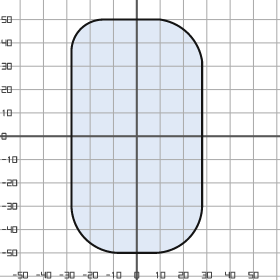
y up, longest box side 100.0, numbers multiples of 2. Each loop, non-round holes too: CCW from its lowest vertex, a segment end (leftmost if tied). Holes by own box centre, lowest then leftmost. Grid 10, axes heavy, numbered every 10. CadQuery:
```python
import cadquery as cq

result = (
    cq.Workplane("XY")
    .moveTo(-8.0, -50.0)
    .lineTo(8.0, -50.0)
    .threePointArc((22.0, -44.0), (28.0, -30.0))
    .lineTo(28.0, 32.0)
    .threePointArc((22.0, 44.0), (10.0, 50.0))
    .lineTo(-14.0, 50.0)
    .threePointArc((-24.0, 46.0), (-28.0, 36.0))
    .lineTo(-28.0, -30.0)
    .threePointArc((-22.0, -44.0), (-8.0, -50.0))
    .close()
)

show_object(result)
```